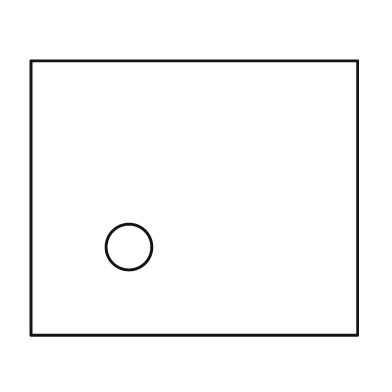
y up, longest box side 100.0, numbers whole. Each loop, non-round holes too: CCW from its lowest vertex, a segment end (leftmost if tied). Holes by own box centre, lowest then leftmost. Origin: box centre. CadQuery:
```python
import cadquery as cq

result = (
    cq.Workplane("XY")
    .moveTo(-50.0, -42.0)
    .lineTo(50.0, -42.0)
    .lineTo(50.0, 42.0)
    .lineTo(-50.0, 42.0)
    .close()
    .moveTo(-20.0, -15.0)
    .circle(7.0)
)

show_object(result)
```